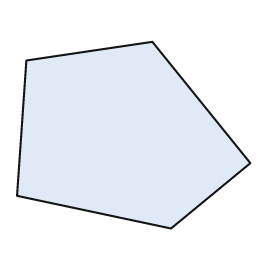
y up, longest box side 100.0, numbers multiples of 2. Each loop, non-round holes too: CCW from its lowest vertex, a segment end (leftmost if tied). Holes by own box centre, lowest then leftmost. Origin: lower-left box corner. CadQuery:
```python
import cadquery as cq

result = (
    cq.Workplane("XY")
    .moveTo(66.0, 0.0)
    .lineTo(100.0, 28.0)
    .lineTo(58.0, 80.0)
    .lineTo(4.0, 72.0)
    .lineTo(0.0, 14.0)
    .close()
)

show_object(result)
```